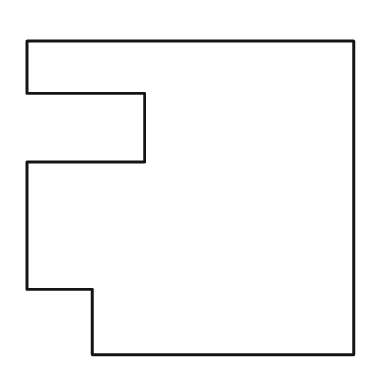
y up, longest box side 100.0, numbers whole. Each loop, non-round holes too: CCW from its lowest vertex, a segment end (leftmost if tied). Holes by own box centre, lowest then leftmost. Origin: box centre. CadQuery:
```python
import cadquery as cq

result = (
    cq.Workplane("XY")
    .moveTo(-30.0, -48.0)
    .lineTo(50.0, -48.0)
    .lineTo(50.0, 48.0)
    .lineTo(-50.0, 48.0)
    .lineTo(-50.0, 32.0)
    .lineTo(-14.0, 32.0)
    .lineTo(-14.0, 11.0)
    .lineTo(-50.0, 11.0)
    .lineTo(-50.0, -28.0)
    .lineTo(-30.0, -28.0)
    .close()
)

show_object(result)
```